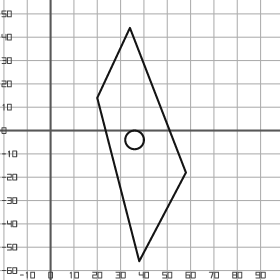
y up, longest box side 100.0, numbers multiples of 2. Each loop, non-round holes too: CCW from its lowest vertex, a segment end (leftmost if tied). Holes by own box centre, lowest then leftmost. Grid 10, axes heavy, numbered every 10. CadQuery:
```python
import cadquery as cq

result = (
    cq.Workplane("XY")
    .moveTo(38.0, -56.0)
    .lineTo(58.0, -18.0)
    .lineTo(34.0, 44.0)
    .lineTo(20.0, 14.0)
    .close()
    .moveTo(36.0, -4.0)
    .circle(4.0)
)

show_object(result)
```